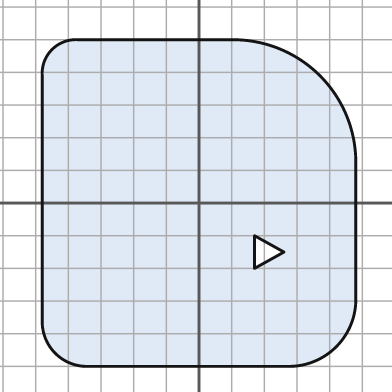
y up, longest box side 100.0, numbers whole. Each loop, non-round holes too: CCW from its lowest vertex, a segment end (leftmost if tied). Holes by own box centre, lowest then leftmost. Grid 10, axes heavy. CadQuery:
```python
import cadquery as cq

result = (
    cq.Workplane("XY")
    .moveTo(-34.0, -50.0)
    .lineTo(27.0, -50.0)
    .threePointArc((42.0, -44.0), (48.0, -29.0))
    .lineTo(48.0, 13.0)
    .threePointArc((37.0, 39.0), (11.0, 50.0))
    .lineTo(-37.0, 50.0)
    .threePointArc((-45.0, 47.0), (-48.0, 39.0))
    .lineTo(-48.0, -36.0)
    .threePointArc((-44.0, -46.0), (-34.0, -50.0))
    .close()
    .moveTo(17.0, -20.0)
    .lineTo(26.0, -15.0)
    .lineTo(17.0, -10.0)
    .close()
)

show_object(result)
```